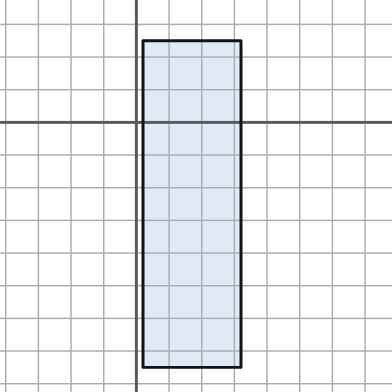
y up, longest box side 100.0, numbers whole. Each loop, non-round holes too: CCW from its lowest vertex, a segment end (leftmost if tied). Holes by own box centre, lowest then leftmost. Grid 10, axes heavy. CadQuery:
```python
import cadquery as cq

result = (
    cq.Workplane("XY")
    .moveTo(2.0, -75.0)
    .lineTo(32.0, -75.0)
    .lineTo(32.0, 25.0)
    .lineTo(2.0, 25.0)
    .close()
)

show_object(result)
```